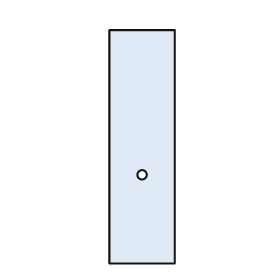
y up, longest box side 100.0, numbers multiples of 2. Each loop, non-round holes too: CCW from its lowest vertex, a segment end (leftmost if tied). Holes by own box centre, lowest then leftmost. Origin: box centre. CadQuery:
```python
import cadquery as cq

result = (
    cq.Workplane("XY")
    .moveTo(-14.0, -50.0)
    .lineTo(14.0, -50.0)
    .lineTo(14.0, 50.0)
    .lineTo(-14.0, 50.0)
    .close()
    .moveTo(0.0, -12.0)
    .circle(2.0)
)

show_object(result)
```